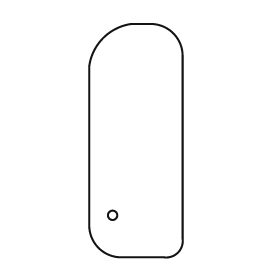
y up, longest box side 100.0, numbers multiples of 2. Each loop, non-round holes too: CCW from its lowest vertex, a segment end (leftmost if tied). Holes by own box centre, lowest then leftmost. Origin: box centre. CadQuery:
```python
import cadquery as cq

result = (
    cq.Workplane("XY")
    .moveTo(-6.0, -50.0)
    .lineTo(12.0, -50.0)
    .threePointArc((18.0, -48.0), (20.0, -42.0))
    .lineTo(20.0, 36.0)
    .threePointArc((16.0, 46.0), (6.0, 50.0))
    .lineTo(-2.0, 50.0)
    .threePointArc((-14.0, 44.0), (-20.0, 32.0))
    .lineTo(-20.0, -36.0)
    .threePointArc((-16.0, -46.0), (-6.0, -50.0))
    .close()
    .moveTo(-10.0, -32.0)
    .circle(2.0)
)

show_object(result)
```